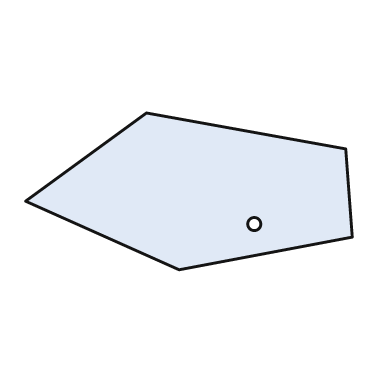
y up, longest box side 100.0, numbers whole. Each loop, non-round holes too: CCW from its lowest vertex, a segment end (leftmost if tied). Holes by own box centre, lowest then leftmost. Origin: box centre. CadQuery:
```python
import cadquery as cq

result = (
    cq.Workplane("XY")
    .moveTo(-3.0, -24.0)
    .lineTo(50.0, -14.0)
    .lineTo(48.0, 13.0)
    .lineTo(-13.0, 24.0)
    .lineTo(-50.0, -3.0)
    .close()
    .moveTo(20.0, -10.0)
    .circle(2.0)
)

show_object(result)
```